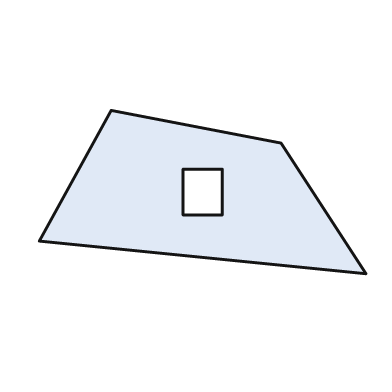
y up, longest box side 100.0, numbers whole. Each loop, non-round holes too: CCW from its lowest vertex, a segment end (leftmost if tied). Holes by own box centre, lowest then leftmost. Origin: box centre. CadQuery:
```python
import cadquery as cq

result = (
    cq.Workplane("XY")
    .moveTo(50.0, -25.0)
    .lineTo(24.0, 15.0)
    .lineTo(-28.0, 25.0)
    .lineTo(-50.0, -15.0)
    .close()
    .moveTo(-6.0, -7.0)
    .lineTo(6.0, -7.0)
    .lineTo(6.0, 7.0)
    .lineTo(-6.0, 7.0)
    .close()
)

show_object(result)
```